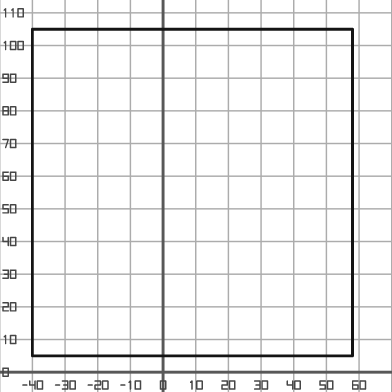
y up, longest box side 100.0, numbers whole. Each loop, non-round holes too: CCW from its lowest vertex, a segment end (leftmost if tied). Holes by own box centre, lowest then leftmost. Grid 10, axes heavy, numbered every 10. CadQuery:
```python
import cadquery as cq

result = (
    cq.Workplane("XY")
    .moveTo(-40.0, 5.0)
    .lineTo(58.0, 5.0)
    .lineTo(58.0, 105.0)
    .lineTo(-40.0, 105.0)
    .close()
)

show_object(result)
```